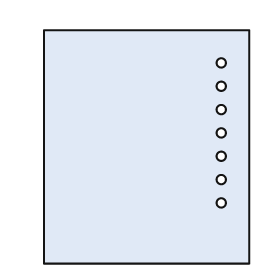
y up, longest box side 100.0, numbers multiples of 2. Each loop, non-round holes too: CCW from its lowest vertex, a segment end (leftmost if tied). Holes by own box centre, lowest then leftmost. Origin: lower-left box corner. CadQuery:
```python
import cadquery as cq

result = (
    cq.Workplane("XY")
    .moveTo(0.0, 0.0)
    .lineTo(88.0, 0.0)
    .lineTo(88.0, 100.0)
    .lineTo(0.0, 100.0)
    .close()
    .moveTo(76.0, 26.0)
    .circle(2.0)
    .moveTo(76.0, 36.0)
    .circle(2.0)
    .moveTo(76.0, 46.0)
    .circle(2.0)
    .moveTo(76.0, 56.0)
    .circle(2.0)
    .moveTo(76.0, 66.0)
    .circle(2.0)
    .moveTo(76.0, 76.0)
    .circle(2.0)
    .moveTo(76.0, 86.0)
    .circle(2.0)
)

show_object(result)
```